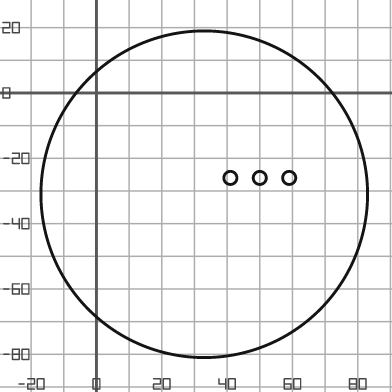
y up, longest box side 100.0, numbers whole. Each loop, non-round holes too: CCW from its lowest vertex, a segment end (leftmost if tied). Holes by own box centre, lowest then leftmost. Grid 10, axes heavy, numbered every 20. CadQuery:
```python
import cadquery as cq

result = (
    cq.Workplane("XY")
    .moveTo(33.0, -31.0)
    .circle(50.0)
    .moveTo(41.0, -26.0)
    .circle(2.0)
    .moveTo(50.0, -26.0)
    .circle(2.0)
    .moveTo(59.0, -26.0)
    .circle(2.0)
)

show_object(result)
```